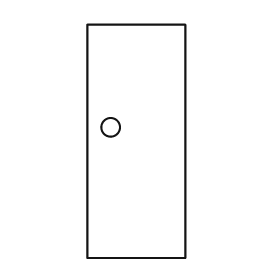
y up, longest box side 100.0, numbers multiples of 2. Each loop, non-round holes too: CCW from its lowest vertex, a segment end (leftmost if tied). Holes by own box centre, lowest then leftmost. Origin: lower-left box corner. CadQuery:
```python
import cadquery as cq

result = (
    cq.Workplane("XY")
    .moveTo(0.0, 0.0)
    .lineTo(42.0, 0.0)
    .lineTo(42.0, 100.0)
    .lineTo(0.0, 100.0)
    .close()
    .moveTo(10.0, 56.0)
    .circle(4.0)
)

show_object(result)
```